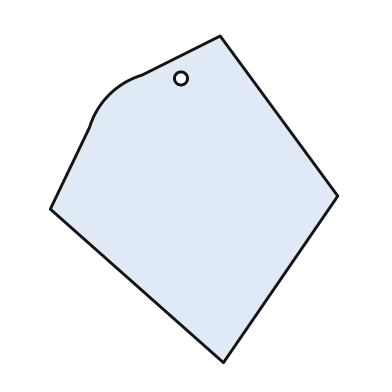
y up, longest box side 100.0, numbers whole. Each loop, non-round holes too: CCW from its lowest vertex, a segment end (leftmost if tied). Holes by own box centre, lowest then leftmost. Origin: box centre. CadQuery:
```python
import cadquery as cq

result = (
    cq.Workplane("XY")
    .moveTo(9.0, -50.0)
    .lineTo(44.0, 1.0)
    .lineTo(8.0, 50.0)
    .lineTo(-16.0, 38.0)
    .threePointArc((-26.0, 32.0), (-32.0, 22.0))
    .lineTo(-44.0, -3.0)
    .close()
    .moveTo(-4.0, 37.0)
    .circle(2.0)
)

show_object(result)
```